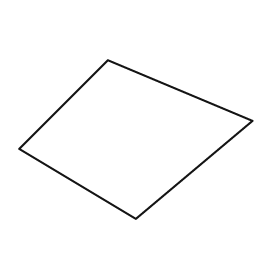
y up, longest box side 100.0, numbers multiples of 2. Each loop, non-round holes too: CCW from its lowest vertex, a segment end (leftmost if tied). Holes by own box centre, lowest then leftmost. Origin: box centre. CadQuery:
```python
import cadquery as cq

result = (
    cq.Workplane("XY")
    .moveTo(0.0, -34.0)
    .lineTo(50.0, 8.0)
    .lineTo(-12.0, 34.0)
    .lineTo(-50.0, -4.0)
    .close()
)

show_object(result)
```